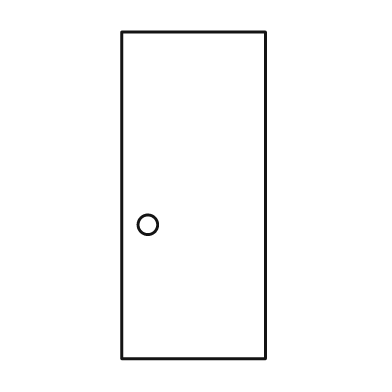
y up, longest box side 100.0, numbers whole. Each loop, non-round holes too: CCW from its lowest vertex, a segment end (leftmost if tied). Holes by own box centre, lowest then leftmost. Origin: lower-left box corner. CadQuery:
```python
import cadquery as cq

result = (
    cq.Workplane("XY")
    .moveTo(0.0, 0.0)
    .lineTo(44.0, 0.0)
    .lineTo(44.0, 100.0)
    .lineTo(0.0, 100.0)
    .close()
    .moveTo(8.0, 41.0)
    .circle(3.0)
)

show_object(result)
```